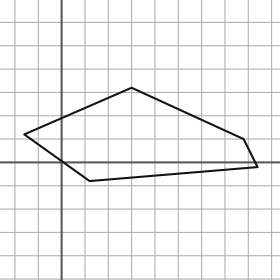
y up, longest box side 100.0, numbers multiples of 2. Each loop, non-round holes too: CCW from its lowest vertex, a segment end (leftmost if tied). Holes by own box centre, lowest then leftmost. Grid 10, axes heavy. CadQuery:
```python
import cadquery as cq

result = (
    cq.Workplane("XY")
    .moveTo(12.0, -8.0)
    .lineTo(84.0, -2.0)
    .lineTo(78.0, 10.0)
    .lineTo(30.0, 32.0)
    .lineTo(-16.0, 12.0)
    .close()
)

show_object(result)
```